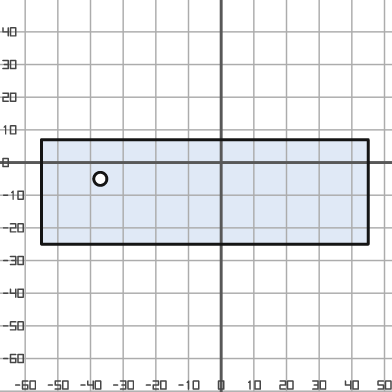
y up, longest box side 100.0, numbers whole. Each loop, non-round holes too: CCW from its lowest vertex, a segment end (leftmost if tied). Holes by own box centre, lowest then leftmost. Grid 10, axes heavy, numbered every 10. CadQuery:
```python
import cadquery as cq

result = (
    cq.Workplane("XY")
    .moveTo(-55.0, -25.0)
    .lineTo(45.0, -25.0)
    .lineTo(45.0, 7.0)
    .lineTo(-55.0, 7.0)
    .close()
    .moveTo(-37.0, -5.0)
    .circle(2.0)
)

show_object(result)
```